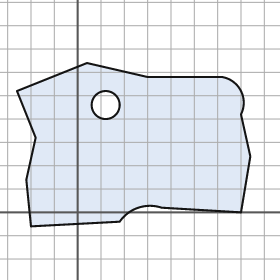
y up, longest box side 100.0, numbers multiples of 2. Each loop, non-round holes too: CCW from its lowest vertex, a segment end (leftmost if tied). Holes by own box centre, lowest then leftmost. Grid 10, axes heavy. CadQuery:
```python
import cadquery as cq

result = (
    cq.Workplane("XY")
    .moveTo(-20.0, -6.0)
    .lineTo(18.0, -4.0)
    .threePointArc((26.0, 2.0), (36.0, 2.0))
    .lineTo(70.0, 0.0)
    .lineTo(74.0, 24.0)
    .lineTo(70.0, 42.0)
    .threePointArc((70.0, 52.0), (62.0, 58.0))
    .lineTo(30.0, 58.0)
    .lineTo(4.0, 64.0)
    .lineTo(-26.0, 52.0)
    .lineTo(-18.0, 32.0)
    .lineTo(-22.0, 14.0)
    .close()
    .moveTo(12.0, 46.0)
    .circle(6.0)
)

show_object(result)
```